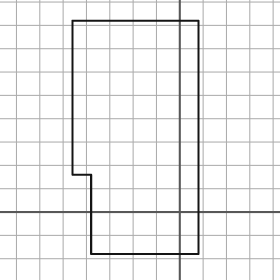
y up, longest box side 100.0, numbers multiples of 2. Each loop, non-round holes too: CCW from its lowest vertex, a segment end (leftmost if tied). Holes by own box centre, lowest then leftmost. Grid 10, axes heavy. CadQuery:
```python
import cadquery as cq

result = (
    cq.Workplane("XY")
    .moveTo(-38.0, -18.0)
    .lineTo(8.0, -18.0)
    .lineTo(8.0, 82.0)
    .lineTo(-46.0, 82.0)
    .lineTo(-46.0, 16.0)
    .lineTo(-38.0, 16.0)
    .close()
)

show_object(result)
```